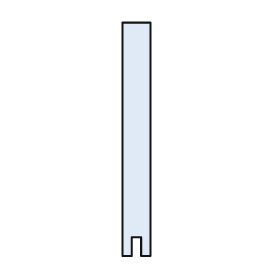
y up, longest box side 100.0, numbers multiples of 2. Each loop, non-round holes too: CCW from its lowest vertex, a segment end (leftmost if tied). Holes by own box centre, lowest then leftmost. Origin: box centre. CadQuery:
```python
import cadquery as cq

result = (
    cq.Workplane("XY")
    .moveTo(-6.0, -50.0)
    .lineTo(-2.0, -50.0)
    .lineTo(-2.0, -42.0)
    .lineTo(2.0, -42.0)
    .lineTo(2.0, -50.0)
    .lineTo(6.0, -50.0)
    .lineTo(6.0, 50.0)
    .lineTo(-6.0, 50.0)
    .close()
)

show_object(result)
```